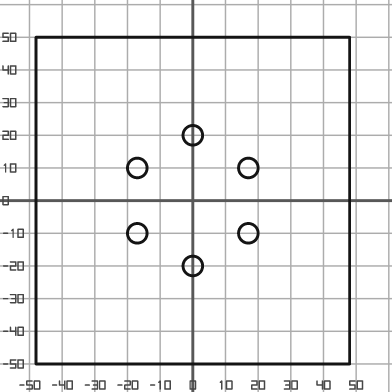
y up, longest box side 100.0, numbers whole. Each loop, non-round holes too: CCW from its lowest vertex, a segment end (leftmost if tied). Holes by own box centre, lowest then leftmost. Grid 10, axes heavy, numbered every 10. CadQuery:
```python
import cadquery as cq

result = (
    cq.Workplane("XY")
    .moveTo(-48.0, -50.0)
    .lineTo(48.0, -50.0)
    .lineTo(48.0, 50.0)
    .lineTo(-48.0, 50.0)
    .close()
    .moveTo(0.0, -20.0)
    .circle(3.0)
    .moveTo(-17.0, -10.0)
    .circle(3.0)
    .moveTo(17.0, -10.0)
    .circle(3.0)
    .moveTo(-17.0, 10.0)
    .circle(3.0)
    .moveTo(17.0, 10.0)
    .circle(3.0)
    .moveTo(0.0, 20.0)
    .circle(3.0)
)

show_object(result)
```